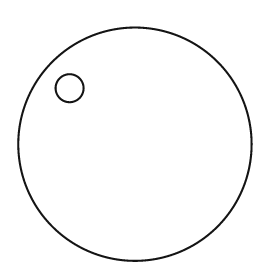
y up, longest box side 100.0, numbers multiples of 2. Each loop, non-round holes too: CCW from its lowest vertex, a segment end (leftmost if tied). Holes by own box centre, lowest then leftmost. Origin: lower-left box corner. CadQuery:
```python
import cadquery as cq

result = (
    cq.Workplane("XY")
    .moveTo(50.0, 50.0)
    .circle(50.0)
    .moveTo(22.0, 74.0)
    .circle(6.0)
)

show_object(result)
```